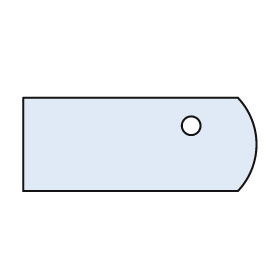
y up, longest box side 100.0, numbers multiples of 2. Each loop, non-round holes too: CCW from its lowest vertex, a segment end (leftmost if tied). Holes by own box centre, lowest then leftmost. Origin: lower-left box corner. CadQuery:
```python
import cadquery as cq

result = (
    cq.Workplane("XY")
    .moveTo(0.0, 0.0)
    .lineTo(92.0, 0.0)
    .threePointArc((100.0, 20.0), (92.0, 40.0))
    .lineTo(0.0, 40.0)
    .close()
    .moveTo(72.0, 28.0)
    .circle(4.0)
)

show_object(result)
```